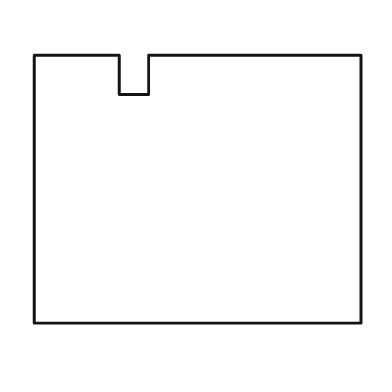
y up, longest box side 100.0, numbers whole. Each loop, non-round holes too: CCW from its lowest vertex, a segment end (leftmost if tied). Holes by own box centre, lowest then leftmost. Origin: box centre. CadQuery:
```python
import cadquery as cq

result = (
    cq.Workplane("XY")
    .moveTo(-50.0, -41.0)
    .lineTo(50.0, -41.0)
    .lineTo(50.0, 41.0)
    .lineTo(-15.0, 41.0)
    .lineTo(-15.0, 29.0)
    .lineTo(-24.0, 29.0)
    .lineTo(-24.0, 41.0)
    .lineTo(-50.0, 41.0)
    .close()
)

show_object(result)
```